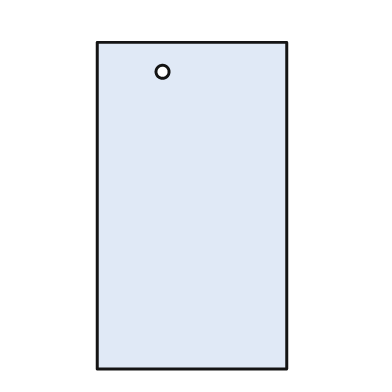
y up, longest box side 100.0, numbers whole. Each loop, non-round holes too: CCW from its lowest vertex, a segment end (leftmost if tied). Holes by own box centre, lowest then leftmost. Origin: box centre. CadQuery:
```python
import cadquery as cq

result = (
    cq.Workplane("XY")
    .moveTo(-29.0, -50.0)
    .lineTo(29.0, -50.0)
    .lineTo(29.0, 50.0)
    .lineTo(-29.0, 50.0)
    .close()
    .moveTo(-9.0, 41.0)
    .circle(2.0)
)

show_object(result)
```